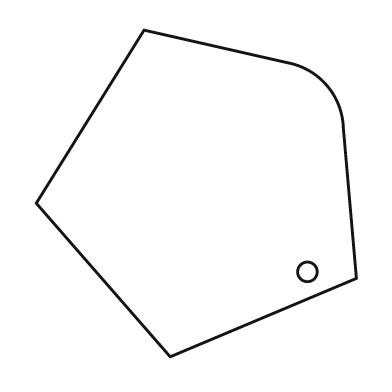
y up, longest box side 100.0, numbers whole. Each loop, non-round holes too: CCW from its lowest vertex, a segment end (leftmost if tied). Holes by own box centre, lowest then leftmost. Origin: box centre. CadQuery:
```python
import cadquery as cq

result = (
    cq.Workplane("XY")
    .moveTo(-8.0, -50.0)
    .lineTo(49.0, -26.0)
    .lineTo(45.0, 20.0)
    .threePointArc((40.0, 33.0), (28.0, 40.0))
    .lineTo(-16.0, 50.0)
    .lineTo(-49.0, -3.0)
    .close()
    .moveTo(34.0, -24.0)
    .circle(3.0)
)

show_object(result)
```